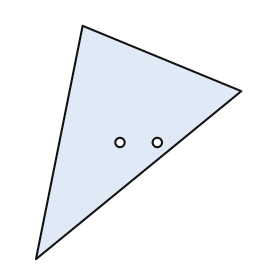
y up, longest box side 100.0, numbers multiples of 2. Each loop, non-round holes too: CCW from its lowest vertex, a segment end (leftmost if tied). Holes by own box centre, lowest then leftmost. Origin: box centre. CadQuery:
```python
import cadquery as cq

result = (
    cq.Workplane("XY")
    .moveTo(-44.0, -50.0)
    .lineTo(44.0, 22.0)
    .lineTo(-24.0, 50.0)
    .close()
    .moveTo(-8.0, 0.0)
    .circle(2.0)
    .moveTo(8.0, 0.0)
    .circle(2.0)
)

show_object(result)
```